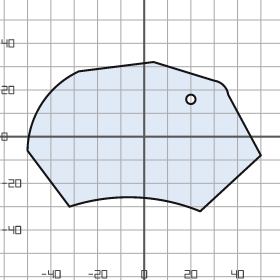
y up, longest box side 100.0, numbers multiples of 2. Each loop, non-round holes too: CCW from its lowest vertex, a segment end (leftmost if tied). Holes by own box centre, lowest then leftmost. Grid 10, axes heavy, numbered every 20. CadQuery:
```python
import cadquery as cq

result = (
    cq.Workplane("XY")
    .moveTo(24.0, -32.0)
    .lineTo(50.0, -8.0)
    .lineTo(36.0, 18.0)
    .threePointArc((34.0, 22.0), (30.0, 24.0))
    .lineTo(4.0, 32.0)
    .lineTo(-28.0, 28.0)
    .threePointArc((-44.0, 14.0), (-50.0, -6.0))
    .lineTo(-32.0, -30.0)
    .threePointArc((-4.0, -26.0), (24.0, -32.0))
    .close()
    .moveTo(20.0, 16.0)
    .circle(2.0)
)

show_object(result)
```